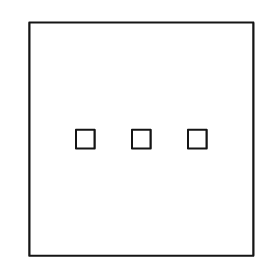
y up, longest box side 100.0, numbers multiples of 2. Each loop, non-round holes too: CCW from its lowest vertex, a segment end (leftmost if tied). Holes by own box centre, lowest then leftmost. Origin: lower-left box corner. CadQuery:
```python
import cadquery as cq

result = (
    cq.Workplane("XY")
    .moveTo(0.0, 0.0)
    .lineTo(96.0, 0.0)
    .lineTo(96.0, 100.0)
    .lineTo(0.0, 100.0)
    .close()
    .moveTo(20.0, 46.0)
    .lineTo(28.0, 46.0)
    .lineTo(28.0, 54.0)
    .lineTo(20.0, 54.0)
    .close()
    .moveTo(44.0, 46.0)
    .lineTo(52.0, 46.0)
    .lineTo(52.0, 54.0)
    .lineTo(44.0, 54.0)
    .close()
    .moveTo(68.0, 46.0)
    .lineTo(76.0, 46.0)
    .lineTo(76.0, 54.0)
    .lineTo(68.0, 54.0)
    .close()
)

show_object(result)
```